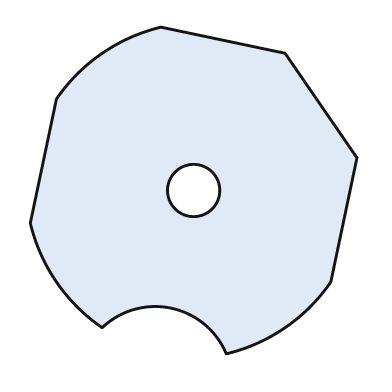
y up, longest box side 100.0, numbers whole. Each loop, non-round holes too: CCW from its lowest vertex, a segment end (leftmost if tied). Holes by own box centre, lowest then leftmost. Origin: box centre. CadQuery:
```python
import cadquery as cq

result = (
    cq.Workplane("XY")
    .moveTo(10.0, -50.0)
    .threePointArc((28.0, -42.0), (42.0, -28.0))
    .lineTo(50.0, 10.0)
    .lineTo(28.0, 42.0)
    .lineTo(-10.0, 50.0)
    .threePointArc((-28.0, 42.0), (-42.0, 28.0))
    .lineTo(-50.0, -10.0)
    .threePointArc((-42.0, -28.0), (-28.0, -42.0))
    .threePointArc((-7.0, -36.0), (10.0, -50.0))
    .close()
    .moveTo(0.0, 0.0)
    .circle(8.0)
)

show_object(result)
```